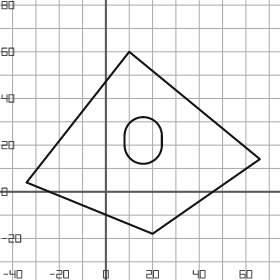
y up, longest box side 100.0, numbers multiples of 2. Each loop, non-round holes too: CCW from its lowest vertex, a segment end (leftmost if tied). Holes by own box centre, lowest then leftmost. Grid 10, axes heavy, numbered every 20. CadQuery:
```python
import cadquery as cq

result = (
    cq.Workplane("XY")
    .moveTo(20.0, -18.0)
    .lineTo(66.0, 14.0)
    .lineTo(10.0, 60.0)
    .lineTo(-34.0, 4.0)
    .close()
    .moveTo(8.0, 20.0)
    .threePointArc((16.0, 12.0), (24.0, 20.0))
    .lineTo(24.0, 24.0)
    .threePointArc((16.0, 32.0), (8.0, 24.0))
    .close()
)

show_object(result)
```